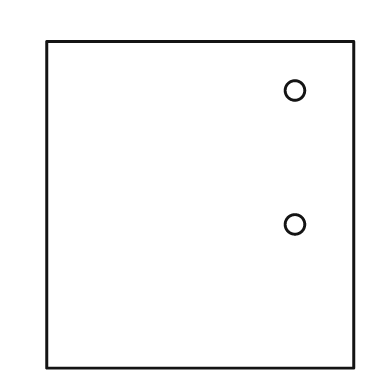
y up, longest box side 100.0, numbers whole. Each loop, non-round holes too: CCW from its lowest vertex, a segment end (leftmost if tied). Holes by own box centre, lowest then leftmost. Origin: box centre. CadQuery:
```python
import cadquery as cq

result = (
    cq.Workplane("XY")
    .moveTo(-47.0, -50.0)
    .lineTo(47.0, -50.0)
    .lineTo(47.0, 50.0)
    .lineTo(-47.0, 50.0)
    .close()
    .moveTo(29.0, -6.0)
    .circle(3.0)
    .moveTo(29.0, 35.0)
    .circle(3.0)
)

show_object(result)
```